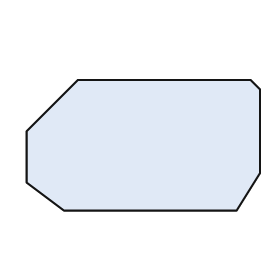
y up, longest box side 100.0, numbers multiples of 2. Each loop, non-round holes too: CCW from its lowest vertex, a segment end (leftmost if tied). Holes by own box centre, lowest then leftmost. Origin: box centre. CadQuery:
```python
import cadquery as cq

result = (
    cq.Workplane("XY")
    .moveTo(-34.0, -28.0)
    .lineTo(40.0, -28.0)
    .lineTo(50.0, -12.0)
    .lineTo(50.0, 24.0)
    .lineTo(46.0, 28.0)
    .lineTo(-28.0, 28.0)
    .lineTo(-50.0, 6.0)
    .lineTo(-50.0, -16.0)
    .close()
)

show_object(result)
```